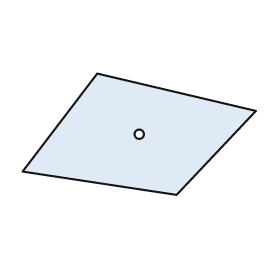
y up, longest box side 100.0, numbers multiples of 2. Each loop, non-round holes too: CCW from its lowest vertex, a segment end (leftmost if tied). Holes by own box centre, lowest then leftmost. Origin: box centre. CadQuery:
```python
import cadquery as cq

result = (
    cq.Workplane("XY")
    .moveTo(16.0, -26.0)
    .lineTo(50.0, 10.0)
    .lineTo(-18.0, 26.0)
    .lineTo(-50.0, -16.0)
    .close()
    .moveTo(0.0, 0.0)
    .circle(2.0)
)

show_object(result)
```